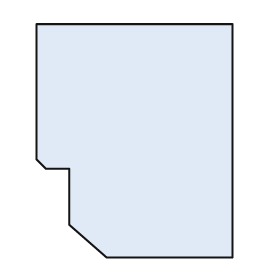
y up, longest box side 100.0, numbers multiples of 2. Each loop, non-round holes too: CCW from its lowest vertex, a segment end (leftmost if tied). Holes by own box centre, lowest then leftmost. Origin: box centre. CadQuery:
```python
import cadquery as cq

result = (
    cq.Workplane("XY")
    .moveTo(-12.0, -50.0)
    .lineTo(42.0, -50.0)
    .lineTo(42.0, 50.0)
    .lineTo(-42.0, 50.0)
    .lineTo(-42.0, -8.0)
    .lineTo(-38.0, -12.0)
    .lineTo(-28.0, -12.0)
    .lineTo(-28.0, -36.0)
    .close()
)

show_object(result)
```